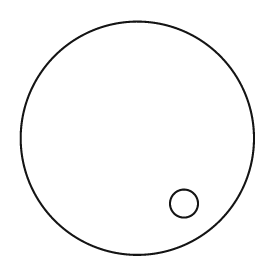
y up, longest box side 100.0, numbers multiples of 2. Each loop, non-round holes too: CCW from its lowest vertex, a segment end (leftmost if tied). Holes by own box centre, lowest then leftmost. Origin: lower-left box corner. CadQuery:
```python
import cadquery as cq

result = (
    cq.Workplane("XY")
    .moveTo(50.0, 50.0)
    .circle(50.0)
    .moveTo(70.0, 22.0)
    .circle(6.0)
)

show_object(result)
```